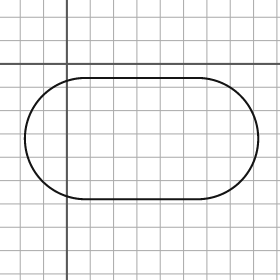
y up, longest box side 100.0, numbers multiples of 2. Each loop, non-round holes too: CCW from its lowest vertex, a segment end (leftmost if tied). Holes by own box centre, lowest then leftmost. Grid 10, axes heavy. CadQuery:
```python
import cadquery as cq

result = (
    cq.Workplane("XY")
    .moveTo(8.0, -58.0)
    .lineTo(56.0, -58.0)
    .threePointArc((82.0, -32.0), (56.0, -6.0))
    .lineTo(8.0, -6.0)
    .threePointArc((-18.0, -32.0), (8.0, -58.0))
    .close()
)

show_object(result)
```